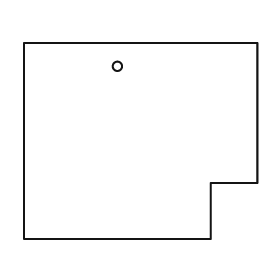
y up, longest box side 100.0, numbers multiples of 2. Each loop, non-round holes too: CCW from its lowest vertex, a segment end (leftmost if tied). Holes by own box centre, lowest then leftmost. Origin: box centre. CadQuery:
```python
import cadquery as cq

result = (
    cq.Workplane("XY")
    .moveTo(-50.0, -42.0)
    .lineTo(30.0, -42.0)
    .lineTo(30.0, -18.0)
    .lineTo(50.0, -18.0)
    .lineTo(50.0, 42.0)
    .lineTo(-50.0, 42.0)
    .close()
    .moveTo(-10.0, 32.0)
    .circle(2.0)
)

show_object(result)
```